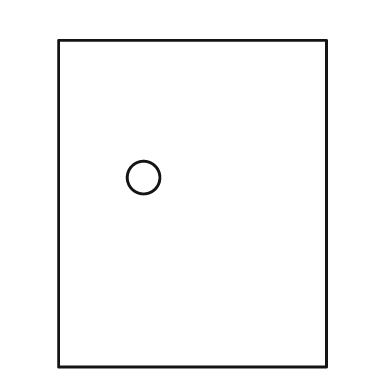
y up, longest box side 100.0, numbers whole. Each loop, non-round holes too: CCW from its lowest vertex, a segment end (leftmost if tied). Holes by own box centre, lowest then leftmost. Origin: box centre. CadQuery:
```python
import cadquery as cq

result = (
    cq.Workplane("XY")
    .moveTo(-41.0, -50.0)
    .lineTo(41.0, -50.0)
    .lineTo(41.0, 50.0)
    .lineTo(-41.0, 50.0)
    .close()
    .moveTo(-15.0, 8.0)
    .circle(5.0)
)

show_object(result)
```